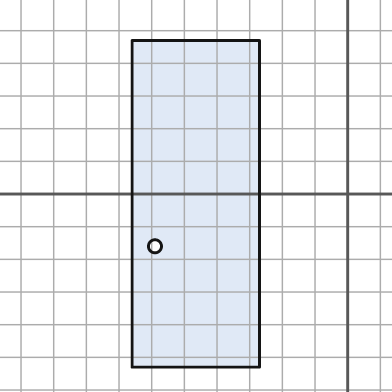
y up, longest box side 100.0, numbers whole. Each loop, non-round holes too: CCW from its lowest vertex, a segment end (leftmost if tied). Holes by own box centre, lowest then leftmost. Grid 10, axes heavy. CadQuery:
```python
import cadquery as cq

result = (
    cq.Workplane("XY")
    .moveTo(-66.0, -53.0)
    .lineTo(-27.0, -53.0)
    .lineTo(-27.0, 47.0)
    .lineTo(-66.0, 47.0)
    .close()
    .moveTo(-59.0, -16.0)
    .circle(2.0)
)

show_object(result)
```